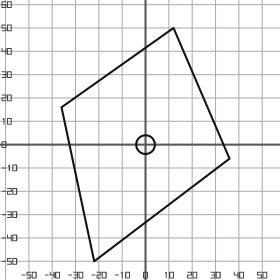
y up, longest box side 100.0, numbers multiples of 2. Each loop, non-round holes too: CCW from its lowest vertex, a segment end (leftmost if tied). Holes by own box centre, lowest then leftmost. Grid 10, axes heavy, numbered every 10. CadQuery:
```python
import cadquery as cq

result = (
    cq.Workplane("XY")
    .moveTo(-22.0, -50.0)
    .lineTo(36.0, -6.0)
    .lineTo(12.0, 50.0)
    .lineTo(-36.0, 16.0)
    .close()
    .moveTo(0.0, 0.0)
    .circle(4.0)
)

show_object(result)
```